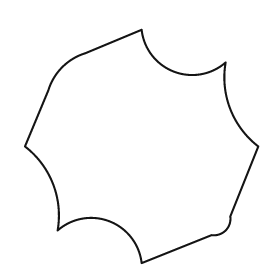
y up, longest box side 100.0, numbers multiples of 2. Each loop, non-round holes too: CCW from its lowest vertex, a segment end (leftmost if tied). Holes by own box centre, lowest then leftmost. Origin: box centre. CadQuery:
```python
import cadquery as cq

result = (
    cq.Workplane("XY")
    .moveTo(0.0, -50.0)
    .lineTo(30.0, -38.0)
    .threePointArc((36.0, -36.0), (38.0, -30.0))
    .lineTo(50.0, 0.0)
    .threePointArc((38.0, 16.0), (36.0, 36.0))
    .threePointArc((14.0, 32.0), (0.0, 50.0))
    .lineTo(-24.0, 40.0)
    .threePointArc((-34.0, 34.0), (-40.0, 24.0))
    .lineTo(-50.0, 0.0)
    .threePointArc((-38.0, -16.0), (-36.0, -36.0))
    .threePointArc((-14.0, -32.0), (0.0, -50.0))
    .close()
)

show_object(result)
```